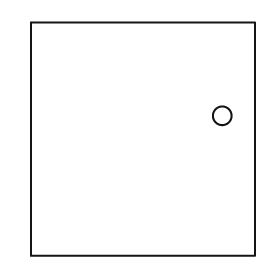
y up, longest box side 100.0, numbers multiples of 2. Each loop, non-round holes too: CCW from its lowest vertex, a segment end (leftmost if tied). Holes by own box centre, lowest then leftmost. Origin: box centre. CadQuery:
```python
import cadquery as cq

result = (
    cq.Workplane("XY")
    .moveTo(-48.0, -50.0)
    .lineTo(48.0, -50.0)
    .lineTo(48.0, 50.0)
    .lineTo(-48.0, 50.0)
    .close()
    .moveTo(34.0, 10.0)
    .circle(4.0)
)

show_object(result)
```